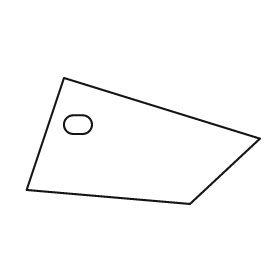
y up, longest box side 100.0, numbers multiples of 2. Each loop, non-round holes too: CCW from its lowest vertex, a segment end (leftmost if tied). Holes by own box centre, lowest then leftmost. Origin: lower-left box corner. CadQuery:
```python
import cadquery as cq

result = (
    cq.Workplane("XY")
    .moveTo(70.0, 0.0)
    .lineTo(100.0, 28.0)
    .lineTo(16.0, 54.0)
    .lineTo(0.0, 6.0)
    .close()
    .moveTo(20.0, 30.0)
    .lineTo(24.0, 30.0)
    .threePointArc((28.0, 34.0), (24.0, 38.0))
    .lineTo(20.0, 38.0)
    .threePointArc((16.0, 34.0), (20.0, 30.0))
    .close()
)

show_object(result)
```